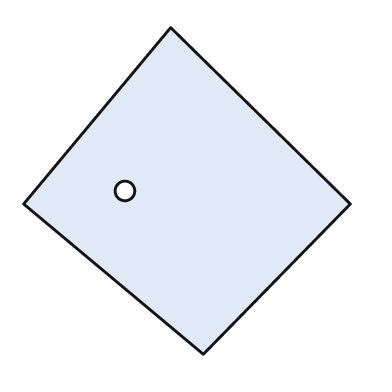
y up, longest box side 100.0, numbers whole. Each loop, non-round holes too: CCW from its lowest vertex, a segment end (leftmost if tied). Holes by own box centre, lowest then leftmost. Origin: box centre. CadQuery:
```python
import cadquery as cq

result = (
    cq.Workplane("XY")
    .moveTo(5.0, -50.0)
    .lineTo(50.0, -4.0)
    .lineTo(-5.0, 50.0)
    .lineTo(-50.0, -4.0)
    .close()
    .moveTo(-19.0, 0.0)
    .circle(3.0)
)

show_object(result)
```